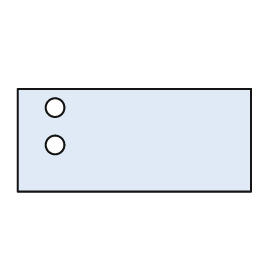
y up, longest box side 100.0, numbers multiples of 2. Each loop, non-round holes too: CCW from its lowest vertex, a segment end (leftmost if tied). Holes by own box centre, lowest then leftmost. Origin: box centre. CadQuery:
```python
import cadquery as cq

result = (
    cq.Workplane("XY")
    .moveTo(-50.0, -22.0)
    .lineTo(50.0, -22.0)
    .lineTo(50.0, 22.0)
    .lineTo(-50.0, 22.0)
    .close()
    .moveTo(-34.0, -2.0)
    .circle(4.0)
    .moveTo(-34.0, 14.0)
    .circle(4.0)
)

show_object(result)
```